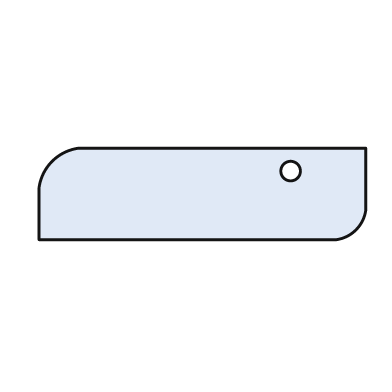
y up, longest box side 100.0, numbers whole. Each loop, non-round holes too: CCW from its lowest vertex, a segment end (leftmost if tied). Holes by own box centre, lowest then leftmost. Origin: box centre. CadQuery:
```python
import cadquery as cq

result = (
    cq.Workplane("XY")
    .moveTo(-50.0, -14.0)
    .lineTo(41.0, -14.0)
    .threePointArc((47.0, -11.0), (50.0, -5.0))
    .lineTo(50.0, 14.0)
    .lineTo(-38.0, 14.0)
    .threePointArc((-46.0, 10.0), (-50.0, 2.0))
    .close()
    .moveTo(27.0, 7.0)
    .circle(3.0)
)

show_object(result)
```